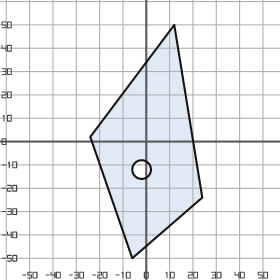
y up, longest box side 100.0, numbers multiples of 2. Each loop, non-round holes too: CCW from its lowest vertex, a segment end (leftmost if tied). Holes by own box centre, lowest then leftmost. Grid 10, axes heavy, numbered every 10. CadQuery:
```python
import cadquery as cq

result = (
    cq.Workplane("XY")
    .moveTo(-6.0, -50.0)
    .lineTo(24.0, -24.0)
    .lineTo(12.0, 50.0)
    .lineTo(-24.0, 2.0)
    .close()
    .moveTo(-2.0, -12.0)
    .circle(4.0)
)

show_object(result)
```